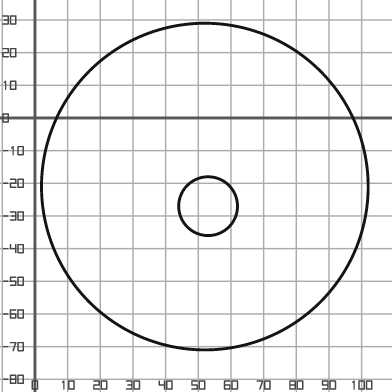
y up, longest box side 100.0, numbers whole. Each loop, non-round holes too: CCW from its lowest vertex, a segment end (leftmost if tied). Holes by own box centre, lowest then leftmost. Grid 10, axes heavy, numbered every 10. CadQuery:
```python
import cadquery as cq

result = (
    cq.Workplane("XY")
    .moveTo(52.0, -21.0)
    .circle(50.0)
    .moveTo(53.0, -27.0)
    .circle(9.0)
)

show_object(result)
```